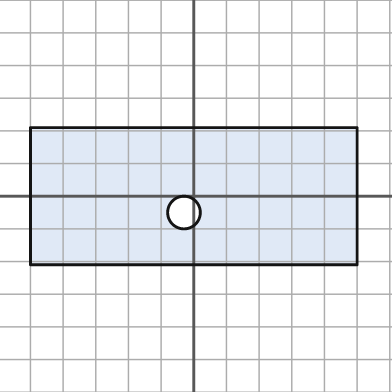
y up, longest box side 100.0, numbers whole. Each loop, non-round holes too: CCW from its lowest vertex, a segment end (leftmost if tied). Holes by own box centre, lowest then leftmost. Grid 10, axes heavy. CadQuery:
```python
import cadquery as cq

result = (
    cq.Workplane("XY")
    .moveTo(-50.0, -21.0)
    .lineTo(50.0, -21.0)
    .lineTo(50.0, 21.0)
    .lineTo(-50.0, 21.0)
    .close()
    .moveTo(-3.0, -5.0)
    .circle(5.0)
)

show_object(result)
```